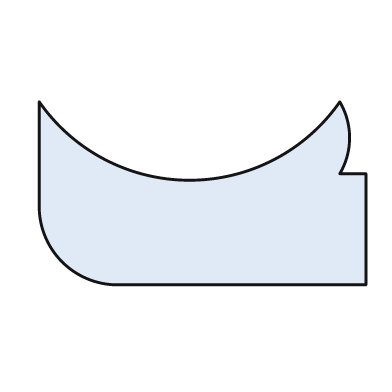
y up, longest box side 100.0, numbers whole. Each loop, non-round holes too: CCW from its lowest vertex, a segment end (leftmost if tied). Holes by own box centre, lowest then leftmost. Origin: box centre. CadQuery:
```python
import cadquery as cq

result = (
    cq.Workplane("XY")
    .moveTo(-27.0, -28.0)
    .lineTo(50.0, -28.0)
    .lineTo(50.0, 6.0)
    .lineTo(42.0, 6.0)
    .threePointArc((45.0, 17.0), (42.0, 28.0))
    .threePointArc((-4.0, 4.0), (-50.0, 28.0))
    .lineTo(-50.0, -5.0)
    .threePointArc((-43.0, -21.0), (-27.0, -28.0))
    .close()
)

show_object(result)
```